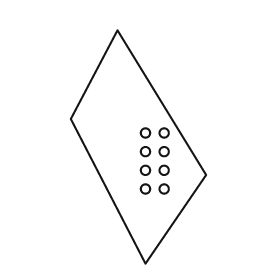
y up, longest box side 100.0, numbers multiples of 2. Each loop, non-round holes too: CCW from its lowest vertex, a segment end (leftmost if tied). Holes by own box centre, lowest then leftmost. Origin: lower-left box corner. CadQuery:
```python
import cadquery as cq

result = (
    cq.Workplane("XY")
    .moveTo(32.0, 0.0)
    .lineTo(58.0, 38.0)
    .lineTo(20.0, 100.0)
    .lineTo(0.0, 62.0)
    .close()
    .moveTo(32.0, 32.0)
    .circle(2.0)
    .moveTo(40.0, 32.0)
    .circle(2.0)
    .moveTo(32.0, 40.0)
    .circle(2.0)
    .moveTo(40.0, 40.0)
    .circle(2.0)
    .moveTo(32.0, 48.0)
    .circle(2.0)
    .moveTo(40.0, 48.0)
    .circle(2.0)
    .moveTo(32.0, 56.0)
    .circle(2.0)
    .moveTo(40.0, 56.0)
    .circle(2.0)
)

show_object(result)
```